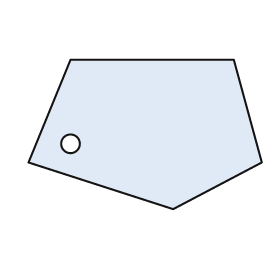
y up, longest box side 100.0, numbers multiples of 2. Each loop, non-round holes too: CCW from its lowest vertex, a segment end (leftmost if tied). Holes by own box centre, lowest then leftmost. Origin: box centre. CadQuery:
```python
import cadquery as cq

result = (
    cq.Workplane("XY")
    .moveTo(12.0, -32.0)
    .lineTo(50.0, -12.0)
    .lineTo(38.0, 32.0)
    .lineTo(-32.0, 32.0)
    .lineTo(-50.0, -12.0)
    .close()
    .moveTo(-32.0, -4.0)
    .circle(4.0)
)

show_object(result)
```